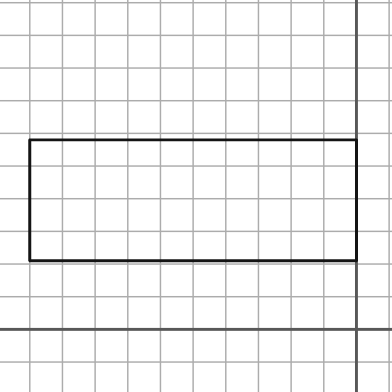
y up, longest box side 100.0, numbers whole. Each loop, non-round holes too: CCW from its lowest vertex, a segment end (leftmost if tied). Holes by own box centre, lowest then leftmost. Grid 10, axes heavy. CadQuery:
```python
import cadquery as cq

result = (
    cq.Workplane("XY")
    .moveTo(-100.0, 21.0)
    .lineTo(0.0, 21.0)
    .lineTo(0.0, 58.0)
    .lineTo(-100.0, 58.0)
    .close()
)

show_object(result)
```